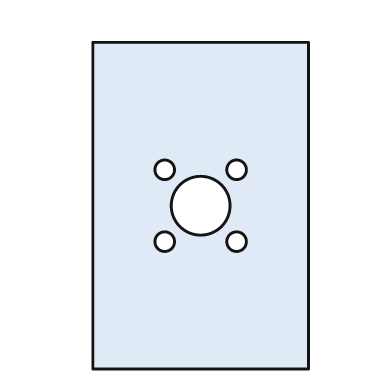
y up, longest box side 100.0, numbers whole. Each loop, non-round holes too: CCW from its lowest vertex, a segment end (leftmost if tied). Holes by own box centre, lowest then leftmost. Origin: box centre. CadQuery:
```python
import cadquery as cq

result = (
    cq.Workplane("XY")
    .moveTo(-33.0, -50.0)
    .lineTo(33.0, -50.0)
    .lineTo(33.0, 50.0)
    .lineTo(-33.0, 50.0)
    .close()
    .moveTo(-11.0, -11.0)
    .circle(3.0)
    .moveTo(11.0, -11.0)
    .circle(3.0)
    .moveTo(0.0, 0.0)
    .circle(9.0)
    .moveTo(-11.0, 11.0)
    .circle(3.0)
    .moveTo(11.0, 11.0)
    .circle(3.0)
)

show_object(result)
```